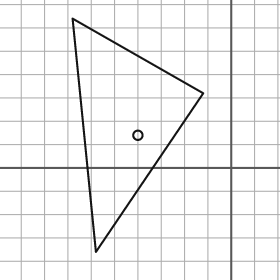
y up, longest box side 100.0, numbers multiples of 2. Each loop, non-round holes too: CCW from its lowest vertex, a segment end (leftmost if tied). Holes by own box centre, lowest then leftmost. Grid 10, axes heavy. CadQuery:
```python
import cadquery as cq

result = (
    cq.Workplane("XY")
    .moveTo(-58.0, -36.0)
    .lineTo(-12.0, 32.0)
    .lineTo(-68.0, 64.0)
    .close()
    .moveTo(-40.0, 14.0)
    .circle(2.0)
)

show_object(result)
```